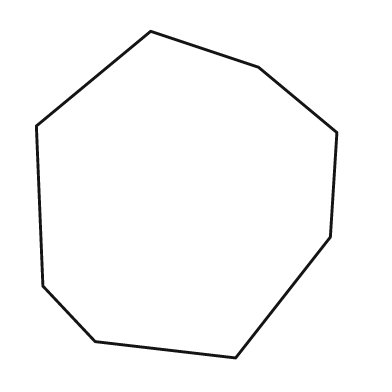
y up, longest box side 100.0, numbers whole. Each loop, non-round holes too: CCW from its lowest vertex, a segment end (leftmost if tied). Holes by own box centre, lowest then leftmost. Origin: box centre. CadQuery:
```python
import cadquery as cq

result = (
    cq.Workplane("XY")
    .moveTo(15.0, -50.0)
    .lineTo(44.0, -13.0)
    .lineTo(46.0, 19.0)
    .lineTo(22.0, 39.0)
    .lineTo(-11.0, 50.0)
    .lineTo(-46.0, 21.0)
    .lineTo(-44.0, -28.0)
    .lineTo(-28.0, -45.0)
    .close()
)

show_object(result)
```